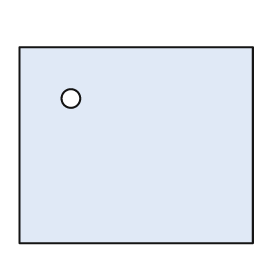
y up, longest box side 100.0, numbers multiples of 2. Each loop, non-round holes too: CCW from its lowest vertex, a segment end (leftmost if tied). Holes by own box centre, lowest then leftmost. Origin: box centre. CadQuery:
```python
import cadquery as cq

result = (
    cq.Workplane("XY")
    .moveTo(-50.0, -42.0)
    .lineTo(50.0, -42.0)
    .lineTo(50.0, 42.0)
    .lineTo(-50.0, 42.0)
    .close()
    .moveTo(-28.0, 20.0)
    .circle(4.0)
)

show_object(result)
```